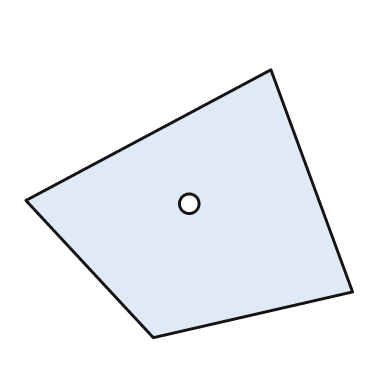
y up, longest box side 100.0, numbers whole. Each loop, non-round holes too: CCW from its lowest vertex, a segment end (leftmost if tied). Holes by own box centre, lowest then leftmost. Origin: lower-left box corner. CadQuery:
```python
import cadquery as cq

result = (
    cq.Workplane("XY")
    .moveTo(39.0, 0.0)
    .lineTo(100.0, 14.0)
    .lineTo(75.0, 82.0)
    .lineTo(0.0, 42.0)
    .close()
    .moveTo(50.0, 41.0)
    .circle(3.0)
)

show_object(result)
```